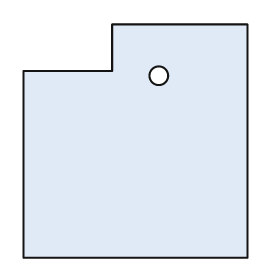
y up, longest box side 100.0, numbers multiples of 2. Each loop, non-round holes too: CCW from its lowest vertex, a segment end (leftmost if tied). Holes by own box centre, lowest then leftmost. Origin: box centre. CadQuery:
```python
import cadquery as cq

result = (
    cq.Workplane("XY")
    .moveTo(-48.0, -50.0)
    .lineTo(48.0, -50.0)
    .lineTo(48.0, 50.0)
    .lineTo(-10.0, 50.0)
    .lineTo(-10.0, 30.0)
    .lineTo(-48.0, 30.0)
    .close()
    .moveTo(10.0, 28.0)
    .circle(4.0)
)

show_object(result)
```